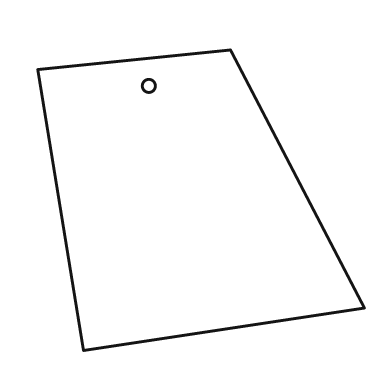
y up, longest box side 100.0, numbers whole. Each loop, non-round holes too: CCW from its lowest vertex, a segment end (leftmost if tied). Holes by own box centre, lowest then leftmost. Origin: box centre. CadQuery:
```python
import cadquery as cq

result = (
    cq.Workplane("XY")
    .moveTo(-36.0, -46.0)
    .lineTo(50.0, -33.0)
    .lineTo(9.0, 46.0)
    .lineTo(-50.0, 40.0)
    .close()
    .moveTo(-16.0, 35.0)
    .circle(2.0)
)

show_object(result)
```